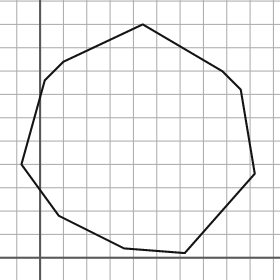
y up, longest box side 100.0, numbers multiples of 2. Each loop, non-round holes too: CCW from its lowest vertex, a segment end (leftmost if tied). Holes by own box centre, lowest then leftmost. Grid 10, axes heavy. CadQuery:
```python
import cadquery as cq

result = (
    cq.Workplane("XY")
    .moveTo(62.0, 2.0)
    .lineTo(92.0, 36.0)
    .lineTo(86.0, 72.0)
    .lineTo(78.0, 80.0)
    .lineTo(44.0, 100.0)
    .lineTo(10.0, 84.0)
    .lineTo(2.0, 76.0)
    .lineTo(-8.0, 40.0)
    .lineTo(8.0, 18.0)
    .lineTo(36.0, 4.0)
    .close()
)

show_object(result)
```